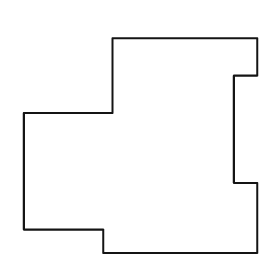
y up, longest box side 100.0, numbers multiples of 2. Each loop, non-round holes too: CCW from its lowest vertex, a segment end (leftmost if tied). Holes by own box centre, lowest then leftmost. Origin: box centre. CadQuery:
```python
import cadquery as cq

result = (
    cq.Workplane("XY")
    .moveTo(-16.0, -46.0)
    .lineTo(50.0, -46.0)
    .lineTo(50.0, -16.0)
    .lineTo(40.0, -16.0)
    .lineTo(40.0, 30.0)
    .lineTo(50.0, 30.0)
    .lineTo(50.0, 46.0)
    .lineTo(-12.0, 46.0)
    .lineTo(-12.0, 14.0)
    .lineTo(-50.0, 14.0)
    .lineTo(-50.0, -36.0)
    .lineTo(-16.0, -36.0)
    .close()
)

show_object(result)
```